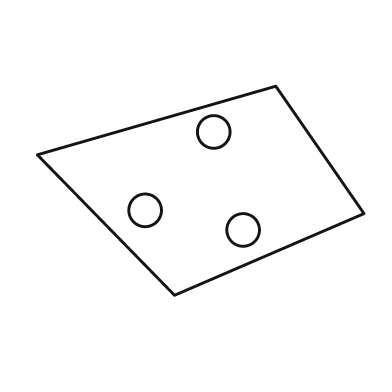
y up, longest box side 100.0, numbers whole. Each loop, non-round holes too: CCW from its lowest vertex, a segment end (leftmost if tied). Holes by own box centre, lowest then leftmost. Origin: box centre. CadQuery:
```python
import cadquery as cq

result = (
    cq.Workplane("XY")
    .moveTo(-8.0, -32.0)
    .lineTo(50.0, -7.0)
    .lineTo(23.0, 32.0)
    .lineTo(-50.0, 11.0)
    .close()
    .moveTo(13.0, -12.0)
    .circle(5.0)
    .moveTo(-17.0, -6.0)
    .circle(5.0)
    .moveTo(4.0, 18.0)
    .circle(5.0)
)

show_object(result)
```